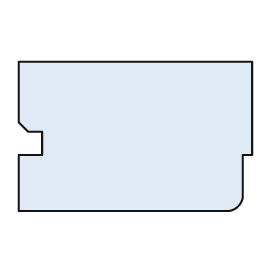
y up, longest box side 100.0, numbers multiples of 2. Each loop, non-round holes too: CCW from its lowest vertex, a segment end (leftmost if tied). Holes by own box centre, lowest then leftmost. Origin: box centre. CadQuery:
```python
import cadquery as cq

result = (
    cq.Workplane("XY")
    .moveTo(-50.0, -32.0)
    .lineTo(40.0, -32.0)
    .threePointArc((44.0, -30.0), (46.0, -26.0))
    .lineTo(46.0, -8.0)
    .lineTo(50.0, -8.0)
    .lineTo(50.0, 32.0)
    .lineTo(-50.0, 32.0)
    .lineTo(-50.0, 6.0)
    .lineTo(-46.0, 2.0)
    .lineTo(-40.0, 2.0)
    .lineTo(-40.0, -8.0)
    .lineTo(-50.0, -8.0)
    .close()
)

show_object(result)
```